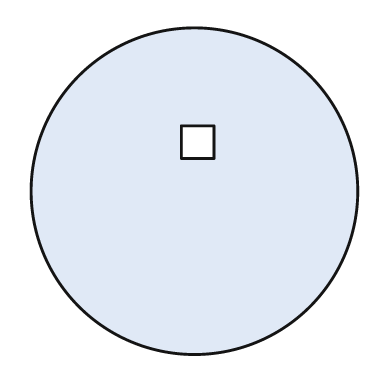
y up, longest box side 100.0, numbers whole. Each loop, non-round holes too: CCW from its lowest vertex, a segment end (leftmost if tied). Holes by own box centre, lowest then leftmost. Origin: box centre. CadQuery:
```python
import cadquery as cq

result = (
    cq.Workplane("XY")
    .moveTo(0.0, 0.0)
    .circle(50.0)
    .moveTo(-4.0, 10.0)
    .lineTo(6.0, 10.0)
    .lineTo(6.0, 20.0)
    .lineTo(-4.0, 20.0)
    .close()
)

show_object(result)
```